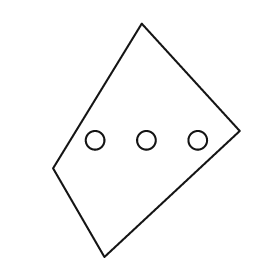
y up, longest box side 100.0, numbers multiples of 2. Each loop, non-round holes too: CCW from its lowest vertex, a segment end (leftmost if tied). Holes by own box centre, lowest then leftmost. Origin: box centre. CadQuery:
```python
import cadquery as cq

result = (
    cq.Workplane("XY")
    .moveTo(-18.0, -50.0)
    .lineTo(40.0, 4.0)
    .lineTo(-2.0, 50.0)
    .lineTo(-40.0, -12.0)
    .close()
    .moveTo(-22.0, 0.0)
    .circle(4.0)
    .moveTo(0.0, 0.0)
    .circle(4.0)
    .moveTo(22.0, 0.0)
    .circle(4.0)
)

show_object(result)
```